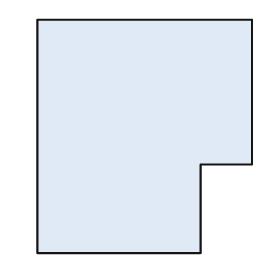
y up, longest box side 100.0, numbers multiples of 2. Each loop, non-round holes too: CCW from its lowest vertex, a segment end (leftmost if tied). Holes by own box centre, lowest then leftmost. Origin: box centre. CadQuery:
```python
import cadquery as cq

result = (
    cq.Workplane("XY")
    .moveTo(-46.0, -50.0)
    .lineTo(24.0, -50.0)
    .lineTo(24.0, -12.0)
    .lineTo(46.0, -12.0)
    .lineTo(46.0, 50.0)
    .lineTo(-46.0, 50.0)
    .close()
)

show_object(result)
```